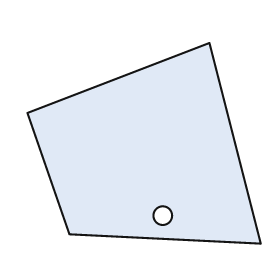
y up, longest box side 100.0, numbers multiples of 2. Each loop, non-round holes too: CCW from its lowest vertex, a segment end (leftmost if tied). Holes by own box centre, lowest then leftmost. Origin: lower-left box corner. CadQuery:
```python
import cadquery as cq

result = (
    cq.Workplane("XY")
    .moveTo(100.0, 0.0)
    .lineTo(78.0, 86.0)
    .lineTo(0.0, 56.0)
    .lineTo(18.0, 4.0)
    .close()
    .moveTo(58.0, 12.0)
    .circle(4.0)
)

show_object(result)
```